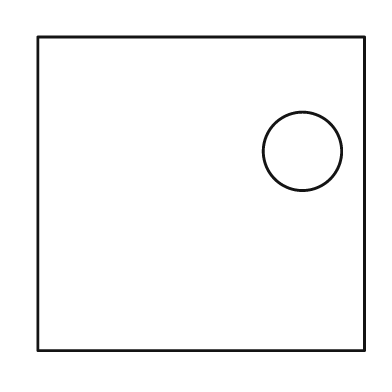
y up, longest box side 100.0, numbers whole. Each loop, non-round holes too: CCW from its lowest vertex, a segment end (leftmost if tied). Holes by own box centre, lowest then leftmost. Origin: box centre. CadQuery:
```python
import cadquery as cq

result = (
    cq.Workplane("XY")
    .moveTo(-50.0, -48.0)
    .lineTo(50.0, -48.0)
    .lineTo(50.0, 48.0)
    .lineTo(-50.0, 48.0)
    .close()
    .moveTo(31.0, 13.0)
    .circle(12.0)
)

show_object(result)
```